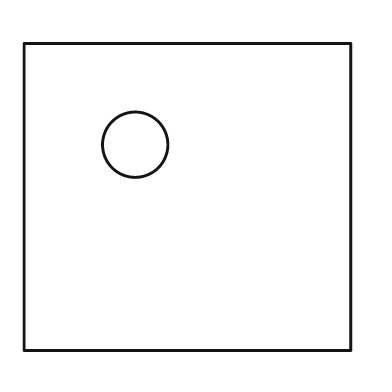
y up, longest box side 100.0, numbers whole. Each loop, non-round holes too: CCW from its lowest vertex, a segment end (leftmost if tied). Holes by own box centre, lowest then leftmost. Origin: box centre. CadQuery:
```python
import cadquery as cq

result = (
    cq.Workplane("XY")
    .moveTo(-50.0, -47.0)
    .lineTo(50.0, -47.0)
    .lineTo(50.0, 47.0)
    .lineTo(-50.0, 47.0)
    .close()
    .moveTo(-16.0, 16.0)
    .circle(10.0)
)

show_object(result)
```